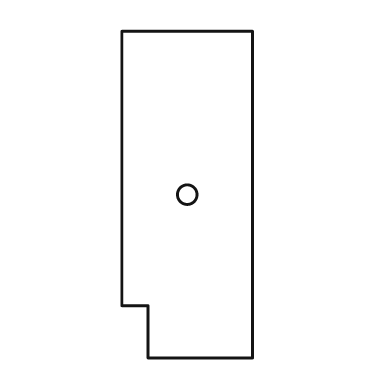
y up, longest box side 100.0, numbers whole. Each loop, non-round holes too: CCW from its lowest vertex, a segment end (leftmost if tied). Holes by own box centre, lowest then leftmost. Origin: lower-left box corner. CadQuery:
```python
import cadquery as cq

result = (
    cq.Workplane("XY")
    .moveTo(8.0, 0.0)
    .lineTo(40.0, 0.0)
    .lineTo(40.0, 100.0)
    .lineTo(0.0, 100.0)
    .lineTo(0.0, 16.0)
    .lineTo(8.0, 16.0)
    .close()
    .moveTo(20.0, 50.0)
    .circle(3.0)
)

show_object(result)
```